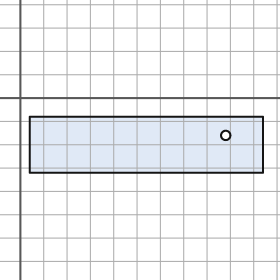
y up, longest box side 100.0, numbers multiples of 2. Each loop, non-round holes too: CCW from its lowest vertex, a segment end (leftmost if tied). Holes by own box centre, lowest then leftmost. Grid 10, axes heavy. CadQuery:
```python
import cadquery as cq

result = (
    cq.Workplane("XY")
    .moveTo(4.0, -32.0)
    .lineTo(104.0, -32.0)
    .lineTo(104.0, -8.0)
    .lineTo(4.0, -8.0)
    .close()
    .moveTo(88.0, -16.0)
    .circle(2.0)
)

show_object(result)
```